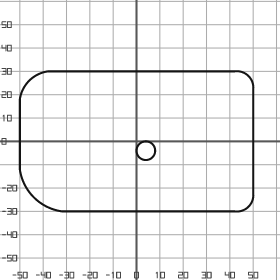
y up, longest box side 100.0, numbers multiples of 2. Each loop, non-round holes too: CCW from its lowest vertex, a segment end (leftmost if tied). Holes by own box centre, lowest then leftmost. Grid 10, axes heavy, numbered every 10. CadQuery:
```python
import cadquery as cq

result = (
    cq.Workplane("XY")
    .moveTo(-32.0, -30.0)
    .lineTo(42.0, -30.0)
    .threePointArc((48.0, -28.0), (50.0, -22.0))
    .lineTo(50.0, 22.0)
    .threePointArc((48.0, 28.0), (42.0, 30.0))
    .lineTo(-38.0, 30.0)
    .threePointArc((-46.0, 26.0), (-50.0, 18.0))
    .lineTo(-50.0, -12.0)
    .threePointArc((-44.0, -24.0), (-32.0, -30.0))
    .close()
    .moveTo(4.0, -4.0)
    .circle(4.0)
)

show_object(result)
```